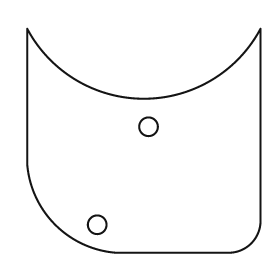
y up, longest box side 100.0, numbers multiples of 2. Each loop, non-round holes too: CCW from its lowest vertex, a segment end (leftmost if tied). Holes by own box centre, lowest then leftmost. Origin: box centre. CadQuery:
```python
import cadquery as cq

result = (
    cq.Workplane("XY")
    .moveTo(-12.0, -48.0)
    .lineTo(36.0, -48.0)
    .threePointArc((46.0, -44.0), (50.0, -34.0))
    .lineTo(50.0, 48.0)
    .threePointArc((0.0, 18.0), (-50.0, 48.0))
    .lineTo(-50.0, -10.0)
    .threePointArc((-38.0, -36.0), (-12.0, -48.0))
    .close()
    .moveTo(-20.0, -36.0)
    .circle(4.0)
    .moveTo(2.0, 6.0)
    .circle(4.0)
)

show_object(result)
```